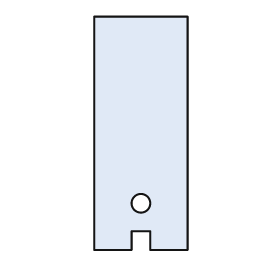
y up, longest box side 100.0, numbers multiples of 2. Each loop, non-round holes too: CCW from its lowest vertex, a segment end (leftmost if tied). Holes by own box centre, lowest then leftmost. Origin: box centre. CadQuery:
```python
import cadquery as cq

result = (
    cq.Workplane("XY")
    .moveTo(-20.0, -50.0)
    .lineTo(-4.0, -50.0)
    .lineTo(-4.0, -42.0)
    .lineTo(4.0, -42.0)
    .lineTo(4.0, -50.0)
    .lineTo(20.0, -50.0)
    .lineTo(20.0, 50.0)
    .lineTo(-20.0, 50.0)
    .close()
    .moveTo(0.0, -30.0)
    .circle(4.0)
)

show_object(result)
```